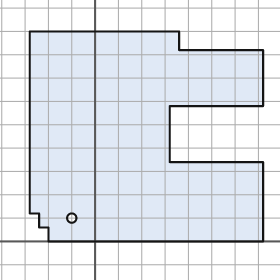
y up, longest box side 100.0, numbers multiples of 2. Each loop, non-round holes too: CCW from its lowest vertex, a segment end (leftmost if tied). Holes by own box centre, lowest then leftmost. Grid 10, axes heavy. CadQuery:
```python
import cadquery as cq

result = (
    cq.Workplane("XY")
    .moveTo(-20.0, 0.0)
    .lineTo(72.0, 0.0)
    .lineTo(72.0, 34.0)
    .lineTo(32.0, 34.0)
    .lineTo(32.0, 58.0)
    .lineTo(72.0, 58.0)
    .lineTo(72.0, 82.0)
    .lineTo(36.0, 82.0)
    .lineTo(36.0, 90.0)
    .lineTo(-28.0, 90.0)
    .lineTo(-28.0, 12.0)
    .lineTo(-24.0, 12.0)
    .lineTo(-24.0, 6.0)
    .lineTo(-20.0, 6.0)
    .close()
    .moveTo(-10.0, 10.0)
    .circle(2.0)
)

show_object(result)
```